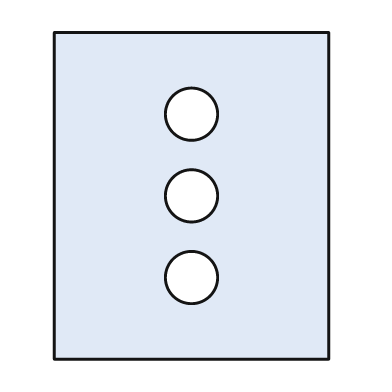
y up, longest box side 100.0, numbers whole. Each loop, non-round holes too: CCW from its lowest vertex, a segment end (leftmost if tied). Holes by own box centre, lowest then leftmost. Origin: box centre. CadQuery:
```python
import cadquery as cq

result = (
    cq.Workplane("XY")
    .moveTo(-42.0, -50.0)
    .lineTo(42.0, -50.0)
    .lineTo(42.0, 50.0)
    .lineTo(-42.0, 50.0)
    .close()
    .moveTo(0.0, -25.0)
    .circle(8.0)
    .moveTo(0.0, 0.0)
    .circle(8.0)
    .moveTo(0.0, 25.0)
    .circle(8.0)
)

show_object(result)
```